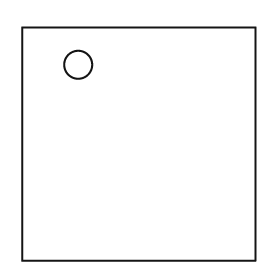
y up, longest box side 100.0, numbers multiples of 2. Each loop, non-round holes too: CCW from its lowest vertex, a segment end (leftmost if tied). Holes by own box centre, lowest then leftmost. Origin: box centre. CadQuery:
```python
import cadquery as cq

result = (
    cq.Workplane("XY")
    .moveTo(-50.0, -50.0)
    .lineTo(50.0, -50.0)
    .lineTo(50.0, 50.0)
    .lineTo(-50.0, 50.0)
    .close()
    .moveTo(-26.0, 34.0)
    .circle(6.0)
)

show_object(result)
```